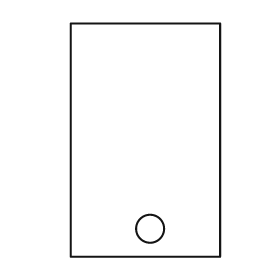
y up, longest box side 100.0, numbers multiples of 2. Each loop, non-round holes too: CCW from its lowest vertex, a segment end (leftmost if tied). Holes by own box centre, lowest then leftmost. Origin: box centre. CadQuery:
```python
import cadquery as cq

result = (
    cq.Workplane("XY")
    .moveTo(-32.0, -50.0)
    .lineTo(32.0, -50.0)
    .lineTo(32.0, 50.0)
    .lineTo(-32.0, 50.0)
    .close()
    .moveTo(2.0, -38.0)
    .circle(6.0)
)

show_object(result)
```